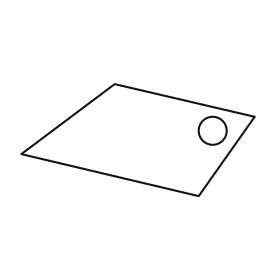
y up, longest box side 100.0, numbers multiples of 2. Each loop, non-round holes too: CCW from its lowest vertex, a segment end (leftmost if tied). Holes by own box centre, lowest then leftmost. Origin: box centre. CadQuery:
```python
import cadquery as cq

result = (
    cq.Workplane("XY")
    .moveTo(26.0, -24.0)
    .lineTo(50.0, 10.0)
    .lineTo(-10.0, 24.0)
    .lineTo(-50.0, -6.0)
    .close()
    .moveTo(32.0, 4.0)
    .circle(6.0)
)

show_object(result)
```